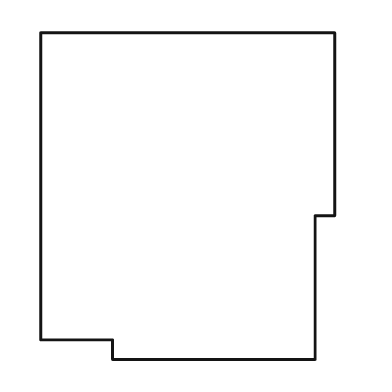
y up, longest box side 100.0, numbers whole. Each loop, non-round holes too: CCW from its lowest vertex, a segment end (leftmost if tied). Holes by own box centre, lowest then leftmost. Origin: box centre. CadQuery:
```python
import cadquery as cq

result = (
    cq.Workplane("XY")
    .moveTo(-23.0, -50.0)
    .lineTo(39.0, -50.0)
    .lineTo(39.0, -6.0)
    .lineTo(45.0, -6.0)
    .lineTo(45.0, 50.0)
    .lineTo(-45.0, 50.0)
    .lineTo(-45.0, -44.0)
    .lineTo(-23.0, -44.0)
    .close()
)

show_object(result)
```